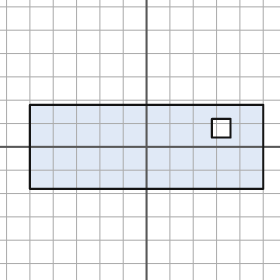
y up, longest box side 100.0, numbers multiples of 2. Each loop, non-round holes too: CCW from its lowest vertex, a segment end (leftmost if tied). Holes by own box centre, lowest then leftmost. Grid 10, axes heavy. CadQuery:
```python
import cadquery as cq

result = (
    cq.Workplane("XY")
    .moveTo(-50.0, -18.0)
    .lineTo(50.0, -18.0)
    .lineTo(50.0, 18.0)
    .lineTo(-50.0, 18.0)
    .close()
    .moveTo(28.0, 4.0)
    .lineTo(36.0, 4.0)
    .lineTo(36.0, 12.0)
    .lineTo(28.0, 12.0)
    .close()
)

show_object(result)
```